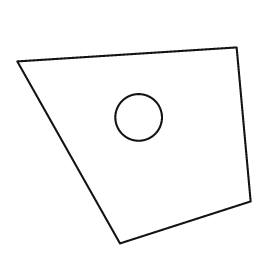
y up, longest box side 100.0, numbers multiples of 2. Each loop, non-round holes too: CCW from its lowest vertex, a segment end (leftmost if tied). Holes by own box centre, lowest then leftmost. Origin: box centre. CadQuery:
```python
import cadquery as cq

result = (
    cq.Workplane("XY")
    .moveTo(-6.0, -42.0)
    .lineTo(50.0, -24.0)
    .lineTo(44.0, 42.0)
    .lineTo(-50.0, 36.0)
    .close()
    .moveTo(2.0, 12.0)
    .circle(10.0)
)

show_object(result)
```